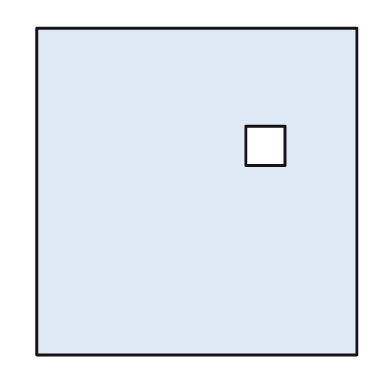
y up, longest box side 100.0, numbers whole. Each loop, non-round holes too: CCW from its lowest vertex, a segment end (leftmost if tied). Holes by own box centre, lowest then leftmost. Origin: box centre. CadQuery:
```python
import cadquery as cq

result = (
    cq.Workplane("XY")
    .moveTo(-49.0, -50.0)
    .lineTo(49.0, -50.0)
    .lineTo(49.0, 50.0)
    .lineTo(-49.0, 50.0)
    .close()
    .moveTo(15.0, 8.0)
    .lineTo(27.0, 8.0)
    .lineTo(27.0, 20.0)
    .lineTo(15.0, 20.0)
    .close()
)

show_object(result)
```